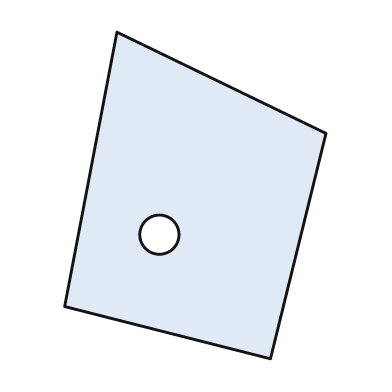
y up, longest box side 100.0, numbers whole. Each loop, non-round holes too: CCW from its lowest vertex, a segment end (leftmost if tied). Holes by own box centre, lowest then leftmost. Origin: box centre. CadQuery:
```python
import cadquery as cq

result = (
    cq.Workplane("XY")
    .moveTo(23.0, -50.0)
    .lineTo(40.0, 19.0)
    .lineTo(-24.0, 50.0)
    .lineTo(-40.0, -34.0)
    .close()
    .moveTo(-11.0, -12.0)
    .circle(6.0)
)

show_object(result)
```